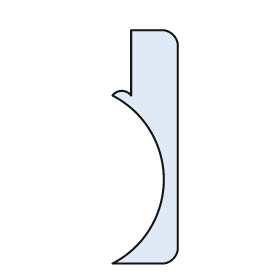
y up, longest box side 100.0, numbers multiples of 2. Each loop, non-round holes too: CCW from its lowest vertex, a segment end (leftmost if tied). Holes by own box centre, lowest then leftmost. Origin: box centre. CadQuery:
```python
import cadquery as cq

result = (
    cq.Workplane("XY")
    .moveTo(-14.0, -50.0)
    .lineTo(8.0, -50.0)
    .threePointArc((12.0, -48.0), (14.0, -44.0))
    .lineTo(14.0, 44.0)
    .threePointArc((12.0, 48.0), (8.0, 50.0))
    .lineTo(-6.0, 50.0)
    .lineTo(-6.0, 22.0)
    .threePointArc((-10.0, 24.0), (-14.0, 22.0))
    .threePointArc((8.0, -14.0), (-14.0, -50.0))
    .close()
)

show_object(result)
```